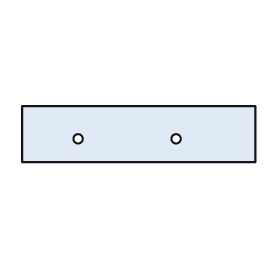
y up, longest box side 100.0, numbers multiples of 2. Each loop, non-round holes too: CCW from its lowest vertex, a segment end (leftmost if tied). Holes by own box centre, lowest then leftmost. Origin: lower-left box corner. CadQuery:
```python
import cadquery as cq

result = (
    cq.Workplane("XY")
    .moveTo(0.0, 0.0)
    .lineTo(100.0, 0.0)
    .lineTo(100.0, 24.0)
    .lineTo(0.0, 24.0)
    .close()
    .moveTo(24.0, 10.0)
    .circle(2.0)
    .moveTo(66.0, 10.0)
    .circle(2.0)
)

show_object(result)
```